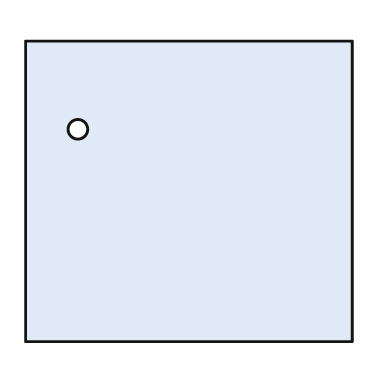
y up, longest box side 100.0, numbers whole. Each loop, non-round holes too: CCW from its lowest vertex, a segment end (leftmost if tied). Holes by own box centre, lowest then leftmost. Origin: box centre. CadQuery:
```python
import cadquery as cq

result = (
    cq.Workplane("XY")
    .moveTo(-50.0, -46.0)
    .lineTo(50.0, -46.0)
    .lineTo(50.0, 46.0)
    .lineTo(-50.0, 46.0)
    .close()
    .moveTo(-34.0, 19.0)
    .circle(3.0)
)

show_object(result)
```